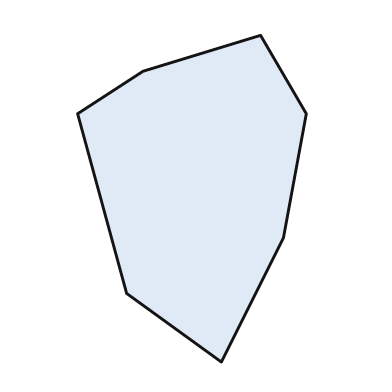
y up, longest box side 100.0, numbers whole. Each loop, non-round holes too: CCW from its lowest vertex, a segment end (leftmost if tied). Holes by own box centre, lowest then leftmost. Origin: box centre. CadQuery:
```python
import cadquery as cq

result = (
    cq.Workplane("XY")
    .moveTo(9.0, -50.0)
    .lineTo(28.0, -12.0)
    .lineTo(35.0, 26.0)
    .lineTo(21.0, 50.0)
    .lineTo(-15.0, 39.0)
    .lineTo(-35.0, 26.0)
    .lineTo(-20.0, -29.0)
    .close()
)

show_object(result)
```